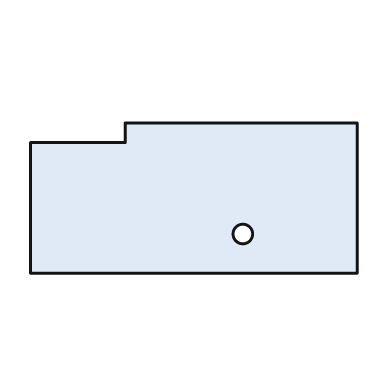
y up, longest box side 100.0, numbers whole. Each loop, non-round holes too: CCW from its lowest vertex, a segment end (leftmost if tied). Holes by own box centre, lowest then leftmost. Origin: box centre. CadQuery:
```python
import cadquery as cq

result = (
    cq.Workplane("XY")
    .moveTo(-50.0, -23.0)
    .lineTo(50.0, -23.0)
    .lineTo(50.0, 23.0)
    .lineTo(-21.0, 23.0)
    .lineTo(-21.0, 17.0)
    .lineTo(-50.0, 17.0)
    .close()
    .moveTo(15.0, -11.0)
    .circle(3.0)
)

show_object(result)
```